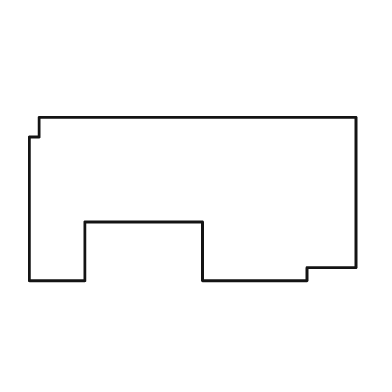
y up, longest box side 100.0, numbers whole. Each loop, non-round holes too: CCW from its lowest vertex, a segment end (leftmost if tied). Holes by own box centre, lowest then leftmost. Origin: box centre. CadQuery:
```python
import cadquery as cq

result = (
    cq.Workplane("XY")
    .moveTo(-50.0, -25.0)
    .lineTo(-33.0, -25.0)
    .lineTo(-33.0, -7.0)
    .lineTo(3.0, -7.0)
    .lineTo(3.0, -25.0)
    .lineTo(35.0, -25.0)
    .lineTo(35.0, -21.0)
    .lineTo(50.0, -21.0)
    .lineTo(50.0, 25.0)
    .lineTo(-47.0, 25.0)
    .lineTo(-47.0, 19.0)
    .lineTo(-50.0, 19.0)
    .close()
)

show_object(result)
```